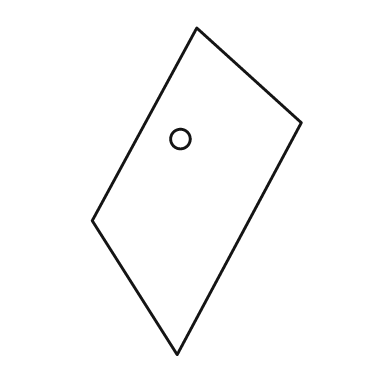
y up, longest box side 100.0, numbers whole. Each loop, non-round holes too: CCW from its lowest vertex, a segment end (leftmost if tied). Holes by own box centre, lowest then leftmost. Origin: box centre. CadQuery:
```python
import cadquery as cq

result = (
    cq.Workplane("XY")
    .moveTo(-6.0, -50.0)
    .lineTo(32.0, 21.0)
    .lineTo(0.0, 50.0)
    .lineTo(-32.0, -9.0)
    .close()
    .moveTo(-5.0, 16.0)
    .circle(3.0)
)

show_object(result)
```